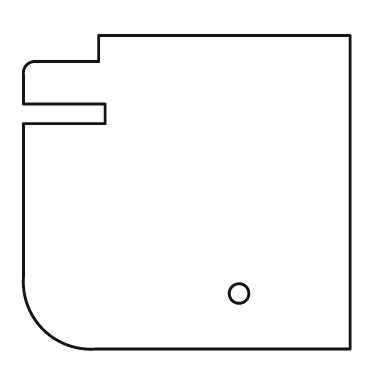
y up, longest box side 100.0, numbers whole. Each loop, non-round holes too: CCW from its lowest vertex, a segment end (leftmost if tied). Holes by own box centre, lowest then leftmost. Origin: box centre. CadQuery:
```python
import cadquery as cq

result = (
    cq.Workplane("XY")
    .moveTo(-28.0, -48.0)
    .lineTo(50.0, -48.0)
    .lineTo(50.0, 48.0)
    .lineTo(-27.0, 48.0)
    .lineTo(-27.0, 40.0)
    .lineTo(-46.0, 40.0)
    .threePointArc((-49.0, 39.0), (-50.0, 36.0))
    .lineTo(-50.0, 27.0)
    .lineTo(-25.0, 27.0)
    .lineTo(-25.0, 21.0)
    .lineTo(-50.0, 21.0)
    .lineTo(-50.0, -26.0)
    .threePointArc((-44.0, -42.0), (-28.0, -48.0))
    .close()
    .moveTo(16.0, -31.0)
    .circle(3.0)
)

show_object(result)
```